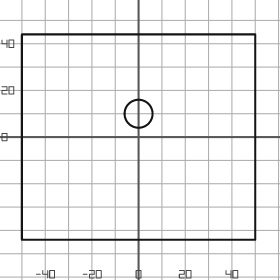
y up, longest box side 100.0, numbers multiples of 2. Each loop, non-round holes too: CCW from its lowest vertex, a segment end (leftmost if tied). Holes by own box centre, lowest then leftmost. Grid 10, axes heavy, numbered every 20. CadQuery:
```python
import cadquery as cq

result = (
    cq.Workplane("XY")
    .moveTo(-50.0, -44.0)
    .lineTo(50.0, -44.0)
    .lineTo(50.0, 44.0)
    .lineTo(-50.0, 44.0)
    .close()
    .moveTo(0.0, 10.0)
    .circle(6.0)
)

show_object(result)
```